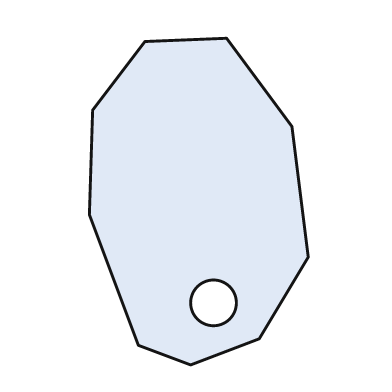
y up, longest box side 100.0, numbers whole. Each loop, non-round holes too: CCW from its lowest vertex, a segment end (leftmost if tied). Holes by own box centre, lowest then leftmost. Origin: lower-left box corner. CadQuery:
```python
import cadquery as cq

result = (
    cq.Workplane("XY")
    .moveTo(31.0, 0.0)
    .lineTo(52.0, 8.0)
    .lineTo(67.0, 33.0)
    .lineTo(62.0, 73.0)
    .lineTo(42.0, 100.0)
    .lineTo(17.0, 99.0)
    .lineTo(1.0, 78.0)
    .lineTo(0.0, 46.0)
    .lineTo(15.0, 6.0)
    .close()
    .moveTo(38.0, 19.0)
    .circle(7.0)
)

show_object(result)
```